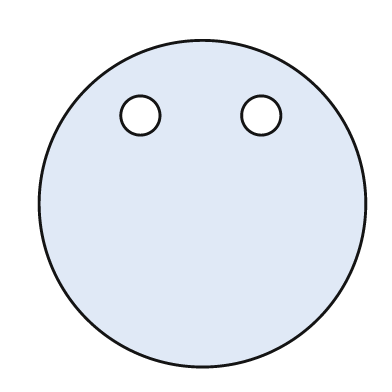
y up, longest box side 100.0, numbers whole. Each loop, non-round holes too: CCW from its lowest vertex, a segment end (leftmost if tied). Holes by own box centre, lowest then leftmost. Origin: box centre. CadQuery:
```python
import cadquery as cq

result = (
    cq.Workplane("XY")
    .moveTo(0.0, 0.0)
    .circle(50.0)
    .moveTo(-19.0, 27.0)
    .circle(6.0)
    .moveTo(18.0, 27.0)
    .circle(6.0)
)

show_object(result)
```